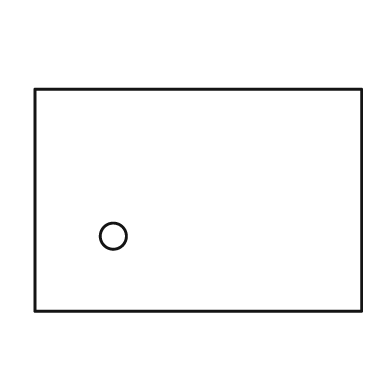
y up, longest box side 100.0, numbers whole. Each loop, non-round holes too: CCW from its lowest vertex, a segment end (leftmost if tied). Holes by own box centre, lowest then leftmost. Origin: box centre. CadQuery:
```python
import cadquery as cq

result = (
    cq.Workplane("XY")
    .moveTo(-50.0, -34.0)
    .lineTo(50.0, -34.0)
    .lineTo(50.0, 34.0)
    .lineTo(-50.0, 34.0)
    .close()
    .moveTo(-26.0, -11.0)
    .circle(4.0)
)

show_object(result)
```